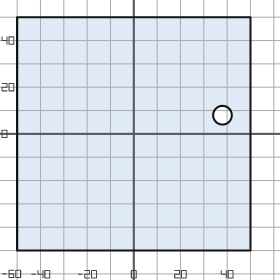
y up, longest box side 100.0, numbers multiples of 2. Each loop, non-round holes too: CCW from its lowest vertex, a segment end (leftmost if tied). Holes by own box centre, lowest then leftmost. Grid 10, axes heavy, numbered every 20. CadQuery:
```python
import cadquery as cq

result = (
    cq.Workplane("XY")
    .moveTo(-50.0, -50.0)
    .lineTo(50.0, -50.0)
    .lineTo(50.0, 50.0)
    .lineTo(-50.0, 50.0)
    .close()
    .moveTo(38.0, 8.0)
    .circle(4.0)
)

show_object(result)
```